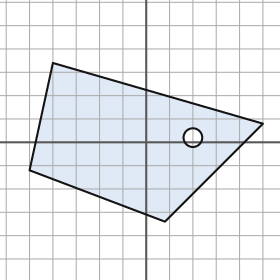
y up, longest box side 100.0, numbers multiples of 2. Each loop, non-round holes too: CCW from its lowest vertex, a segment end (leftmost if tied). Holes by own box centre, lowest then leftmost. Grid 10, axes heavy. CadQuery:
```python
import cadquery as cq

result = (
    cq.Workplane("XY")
    .moveTo(8.0, -34.0)
    .lineTo(50.0, 8.0)
    .lineTo(-40.0, 34.0)
    .lineTo(-50.0, -12.0)
    .close()
    .moveTo(20.0, 2.0)
    .circle(4.0)
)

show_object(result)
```